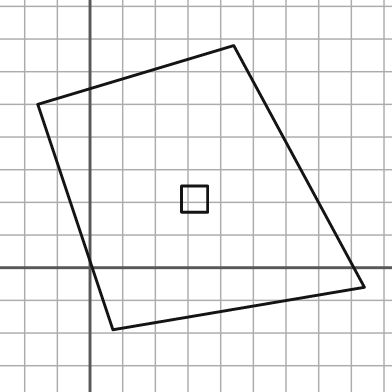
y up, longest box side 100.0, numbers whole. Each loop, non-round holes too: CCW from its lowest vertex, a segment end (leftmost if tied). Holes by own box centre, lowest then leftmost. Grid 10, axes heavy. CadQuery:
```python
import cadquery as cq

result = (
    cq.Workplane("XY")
    .moveTo(7.0, -19.0)
    .lineTo(84.0, -6.0)
    .lineTo(44.0, 68.0)
    .lineTo(-16.0, 50.0)
    .close()
    .moveTo(28.0, 17.0)
    .lineTo(36.0, 17.0)
    .lineTo(36.0, 25.0)
    .lineTo(28.0, 25.0)
    .close()
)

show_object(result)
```